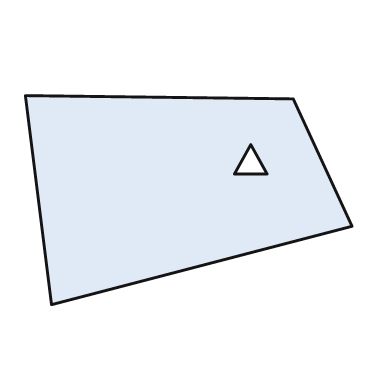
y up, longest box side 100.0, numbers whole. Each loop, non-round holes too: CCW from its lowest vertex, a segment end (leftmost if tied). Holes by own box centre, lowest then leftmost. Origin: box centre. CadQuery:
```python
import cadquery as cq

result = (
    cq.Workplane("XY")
    .moveTo(-42.0, -32.0)
    .lineTo(50.0, -8.0)
    .lineTo(32.0, 31.0)
    .lineTo(-50.0, 32.0)
    .close()
    .moveTo(14.0, 8.0)
    .lineTo(24.0, 8.0)
    .lineTo(19.0, 17.0)
    .close()
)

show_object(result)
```